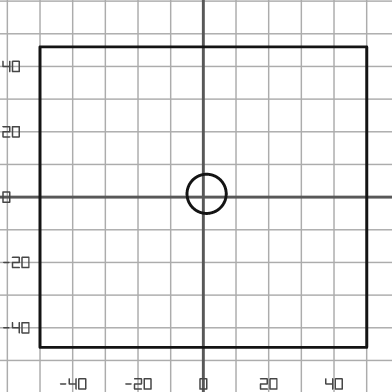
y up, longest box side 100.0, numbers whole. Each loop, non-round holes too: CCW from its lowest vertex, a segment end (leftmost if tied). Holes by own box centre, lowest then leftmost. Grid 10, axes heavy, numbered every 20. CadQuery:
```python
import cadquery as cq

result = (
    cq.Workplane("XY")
    .moveTo(-50.0, -46.0)
    .lineTo(50.0, -46.0)
    .lineTo(50.0, 46.0)
    .lineTo(-50.0, 46.0)
    .close()
    .moveTo(1.0, 1.0)
    .circle(6.0)
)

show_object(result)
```